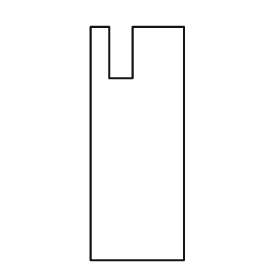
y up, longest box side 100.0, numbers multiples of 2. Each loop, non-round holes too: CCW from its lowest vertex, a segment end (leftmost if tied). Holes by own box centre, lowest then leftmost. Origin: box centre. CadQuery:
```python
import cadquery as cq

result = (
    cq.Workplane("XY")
    .moveTo(-20.0, -50.0)
    .lineTo(20.0, -50.0)
    .lineTo(20.0, 50.0)
    .lineTo(-2.0, 50.0)
    .lineTo(-2.0, 28.0)
    .lineTo(-12.0, 28.0)
    .lineTo(-12.0, 50.0)
    .lineTo(-20.0, 50.0)
    .close()
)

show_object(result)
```